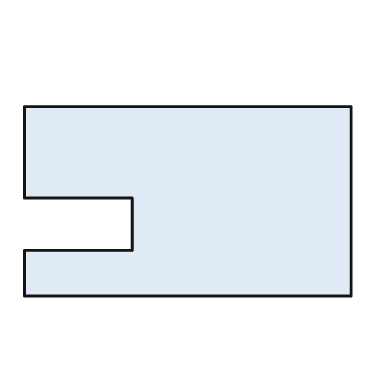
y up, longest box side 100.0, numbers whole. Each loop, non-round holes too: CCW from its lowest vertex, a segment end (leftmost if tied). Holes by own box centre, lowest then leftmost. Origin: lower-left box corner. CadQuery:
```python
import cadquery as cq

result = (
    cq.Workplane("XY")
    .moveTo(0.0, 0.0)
    .lineTo(100.0, 0.0)
    .lineTo(100.0, 58.0)
    .lineTo(0.0, 58.0)
    .lineTo(0.0, 30.0)
    .lineTo(33.0, 30.0)
    .lineTo(33.0, 14.0)
    .lineTo(0.0, 14.0)
    .close()
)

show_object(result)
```